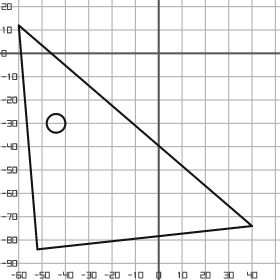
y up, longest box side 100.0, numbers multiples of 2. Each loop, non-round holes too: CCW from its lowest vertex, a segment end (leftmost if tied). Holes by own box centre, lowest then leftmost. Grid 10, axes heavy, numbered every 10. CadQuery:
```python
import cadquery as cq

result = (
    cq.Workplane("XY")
    .moveTo(-52.0, -84.0)
    .lineTo(40.0, -74.0)
    .lineTo(-60.0, 12.0)
    .close()
    .moveTo(-44.0, -30.0)
    .circle(4.0)
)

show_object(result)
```